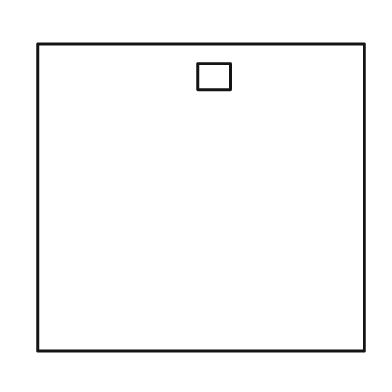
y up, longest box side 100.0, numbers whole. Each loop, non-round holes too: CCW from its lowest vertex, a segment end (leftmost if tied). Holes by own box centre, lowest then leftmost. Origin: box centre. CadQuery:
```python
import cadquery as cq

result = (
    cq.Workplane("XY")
    .moveTo(-50.0, -47.0)
    .lineTo(50.0, -47.0)
    .lineTo(50.0, 47.0)
    .lineTo(-50.0, 47.0)
    .close()
    .moveTo(-1.0, 33.0)
    .lineTo(9.0, 33.0)
    .lineTo(9.0, 41.0)
    .lineTo(-1.0, 41.0)
    .close()
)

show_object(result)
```